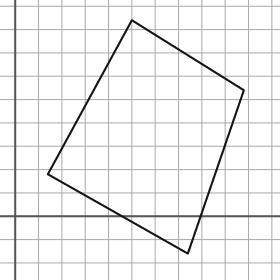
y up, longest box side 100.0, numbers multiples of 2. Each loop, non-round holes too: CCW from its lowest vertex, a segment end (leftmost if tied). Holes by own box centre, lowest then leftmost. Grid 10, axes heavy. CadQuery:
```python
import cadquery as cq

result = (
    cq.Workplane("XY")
    .moveTo(74.0, -16.0)
    .lineTo(98.0, 54.0)
    .lineTo(50.0, 84.0)
    .lineTo(14.0, 18.0)
    .close()
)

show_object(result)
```